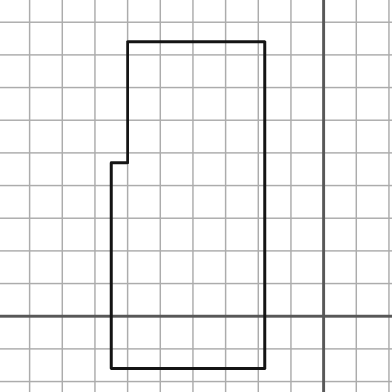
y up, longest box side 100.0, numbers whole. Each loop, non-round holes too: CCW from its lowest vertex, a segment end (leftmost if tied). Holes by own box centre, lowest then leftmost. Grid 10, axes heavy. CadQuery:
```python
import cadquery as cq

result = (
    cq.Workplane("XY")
    .moveTo(-65.0, -16.0)
    .lineTo(-18.0, -16.0)
    .lineTo(-18.0, 84.0)
    .lineTo(-60.0, 84.0)
    .lineTo(-60.0, 47.0)
    .lineTo(-65.0, 47.0)
    .close()
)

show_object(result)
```